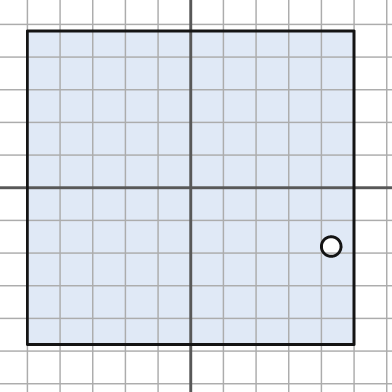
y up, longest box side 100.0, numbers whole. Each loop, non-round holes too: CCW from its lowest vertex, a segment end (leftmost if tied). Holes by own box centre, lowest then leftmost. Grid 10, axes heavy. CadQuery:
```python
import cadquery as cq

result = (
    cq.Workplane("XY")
    .moveTo(-50.0, -48.0)
    .lineTo(50.0, -48.0)
    .lineTo(50.0, 48.0)
    .lineTo(-50.0, 48.0)
    .close()
    .moveTo(43.0, -18.0)
    .circle(3.0)
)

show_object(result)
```